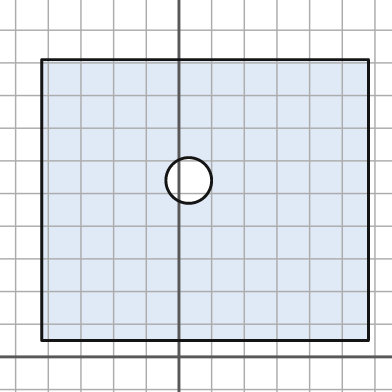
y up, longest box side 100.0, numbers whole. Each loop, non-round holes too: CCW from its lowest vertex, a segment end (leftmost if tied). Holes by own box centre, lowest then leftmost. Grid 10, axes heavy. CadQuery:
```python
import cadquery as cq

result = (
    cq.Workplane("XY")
    .moveTo(-42.0, 5.0)
    .lineTo(58.0, 5.0)
    .lineTo(58.0, 91.0)
    .lineTo(-42.0, 91.0)
    .close()
    .moveTo(3.0, 54.0)
    .circle(7.0)
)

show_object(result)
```